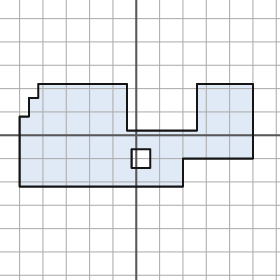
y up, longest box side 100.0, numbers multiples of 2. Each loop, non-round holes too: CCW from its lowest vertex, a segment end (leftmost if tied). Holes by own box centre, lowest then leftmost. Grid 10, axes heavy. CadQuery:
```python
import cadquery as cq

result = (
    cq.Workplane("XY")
    .moveTo(-50.0, -22.0)
    .lineTo(20.0, -22.0)
    .lineTo(20.0, -10.0)
    .lineTo(50.0, -10.0)
    .lineTo(50.0, 22.0)
    .lineTo(26.0, 22.0)
    .lineTo(26.0, 2.0)
    .lineTo(-4.0, 2.0)
    .lineTo(-4.0, 22.0)
    .lineTo(-42.0, 22.0)
    .lineTo(-42.0, 16.0)
    .lineTo(-46.0, 16.0)
    .lineTo(-46.0, 8.0)
    .lineTo(-50.0, 8.0)
    .close()
    .moveTo(-2.0, -14.0)
    .lineTo(6.0, -14.0)
    .lineTo(6.0, -6.0)
    .lineTo(-2.0, -6.0)
    .close()
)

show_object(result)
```